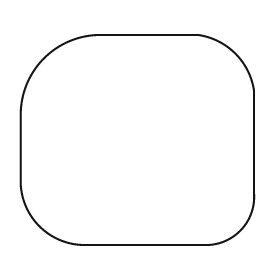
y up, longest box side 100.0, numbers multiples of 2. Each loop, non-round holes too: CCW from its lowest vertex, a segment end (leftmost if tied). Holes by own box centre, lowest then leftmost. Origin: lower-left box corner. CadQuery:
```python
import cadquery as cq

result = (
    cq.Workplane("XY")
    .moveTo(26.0, 0.0)
    .lineTo(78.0, 0.0)
    .threePointArc((94.0, 6.0), (100.0, 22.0))
    .lineTo(100.0, 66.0)
    .threePointArc((92.0, 82.0), (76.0, 90.0))
    .lineTo(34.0, 90.0)
    .threePointArc((10.0, 80.0), (0.0, 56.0))
    .lineTo(0.0, 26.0)
    .threePointArc((8.0, 8.0), (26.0, 0.0))
    .close()
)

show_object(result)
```